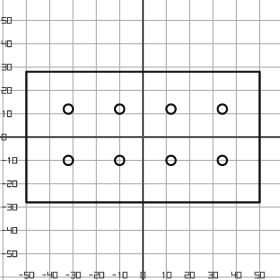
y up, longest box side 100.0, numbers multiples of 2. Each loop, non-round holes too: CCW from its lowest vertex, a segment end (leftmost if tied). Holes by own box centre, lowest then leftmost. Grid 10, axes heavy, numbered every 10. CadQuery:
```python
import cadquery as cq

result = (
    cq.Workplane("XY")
    .moveTo(-50.0, -28.0)
    .lineTo(50.0, -28.0)
    .lineTo(50.0, 28.0)
    .lineTo(-50.0, 28.0)
    .close()
    .moveTo(-32.0, -10.0)
    .circle(2.0)
    .moveTo(-10.0, -10.0)
    .circle(2.0)
    .moveTo(12.0, -10.0)
    .circle(2.0)
    .moveTo(34.0, -10.0)
    .circle(2.0)
    .moveTo(-32.0, 12.0)
    .circle(2.0)
    .moveTo(-10.0, 12.0)
    .circle(2.0)
    .moveTo(12.0, 12.0)
    .circle(2.0)
    .moveTo(34.0, 12.0)
    .circle(2.0)
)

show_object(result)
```